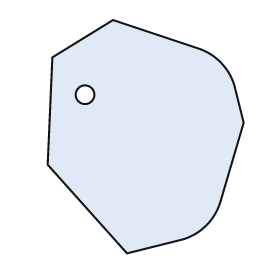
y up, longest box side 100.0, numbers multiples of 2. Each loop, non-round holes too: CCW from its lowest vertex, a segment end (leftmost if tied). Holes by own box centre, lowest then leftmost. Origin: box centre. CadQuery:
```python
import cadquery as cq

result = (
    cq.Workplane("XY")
    .moveTo(-8.0, -50.0)
    .lineTo(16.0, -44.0)
    .threePointArc((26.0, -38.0), (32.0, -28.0))
    .lineTo(42.0, 6.0)
    .lineTo(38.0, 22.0)
    .threePointArc((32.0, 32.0), (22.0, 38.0))
    .lineTo(-14.0, 50.0)
    .lineTo(-40.0, 34.0)
    .lineTo(-42.0, -12.0)
    .close()
    .moveTo(-26.0, 18.0)
    .circle(4.0)
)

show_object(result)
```